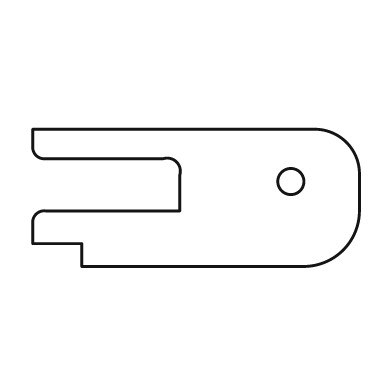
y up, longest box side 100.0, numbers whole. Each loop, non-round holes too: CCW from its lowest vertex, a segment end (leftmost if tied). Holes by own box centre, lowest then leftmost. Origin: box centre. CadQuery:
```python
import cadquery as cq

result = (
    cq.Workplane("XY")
    .moveTo(-35.0, -21.0)
    .lineTo(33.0, -21.0)
    .threePointArc((45.0, -16.0), (50.0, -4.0))
    .lineTo(50.0, 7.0)
    .threePointArc((46.0, 17.0), (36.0, 21.0))
    .lineTo(-50.0, 21.0)
    .lineTo(-50.0, 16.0)
    .threePointArc((-49.0, 13.0), (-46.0, 12.0))
    .lineTo(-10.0, 12.0)
    .threePointArc((-6.0, 11.0), (-5.0, 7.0))
    .lineTo(-5.0, -4.0)
    .lineTo(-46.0, -4.0)
    .threePointArc((-49.0, -5.0), (-50.0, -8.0))
    .lineTo(-50.0, -14.0)
    .lineTo(-35.0, -14.0)
    .close()
    .moveTo(29.0, 5.0)
    .circle(4.0)
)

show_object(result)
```